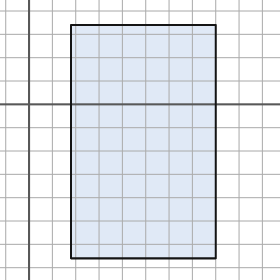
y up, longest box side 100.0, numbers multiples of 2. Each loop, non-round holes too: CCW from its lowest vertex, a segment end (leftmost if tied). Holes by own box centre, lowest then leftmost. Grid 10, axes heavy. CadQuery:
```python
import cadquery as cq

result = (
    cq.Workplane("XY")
    .moveTo(18.0, -66.0)
    .lineTo(80.0, -66.0)
    .lineTo(80.0, 34.0)
    .lineTo(18.0, 34.0)
    .close()
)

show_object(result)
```